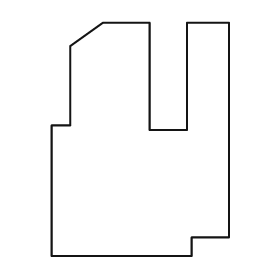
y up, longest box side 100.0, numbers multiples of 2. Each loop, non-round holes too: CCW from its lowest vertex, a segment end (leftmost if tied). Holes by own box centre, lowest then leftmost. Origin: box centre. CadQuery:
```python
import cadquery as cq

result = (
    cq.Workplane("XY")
    .moveTo(-38.0, -50.0)
    .lineTo(22.0, -50.0)
    .lineTo(22.0, -42.0)
    .lineTo(38.0, -42.0)
    .lineTo(38.0, 50.0)
    .lineTo(20.0, 50.0)
    .lineTo(20.0, 4.0)
    .lineTo(4.0, 4.0)
    .lineTo(4.0, 50.0)
    .lineTo(-16.0, 50.0)
    .lineTo(-30.0, 40.0)
    .lineTo(-30.0, 6.0)
    .lineTo(-38.0, 6.0)
    .close()
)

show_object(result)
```